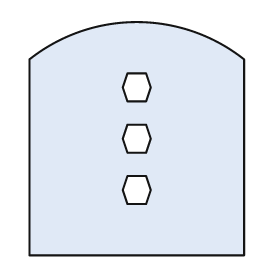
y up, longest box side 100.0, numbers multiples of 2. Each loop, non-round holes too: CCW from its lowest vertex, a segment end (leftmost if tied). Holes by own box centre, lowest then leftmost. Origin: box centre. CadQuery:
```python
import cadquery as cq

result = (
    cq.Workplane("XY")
    .moveTo(-46.0, -50.0)
    .lineTo(46.0, -50.0)
    .lineTo(46.0, 34.0)
    .threePointArc((0.0, 50.0), (-46.0, 34.0))
    .close()
    .moveTo(-4.0, -28.0)
    .lineTo(4.0, -28.0)
    .lineTo(6.0, -22.0)
    .lineTo(4.0, -16.0)
    .lineTo(-4.0, -16.0)
    .lineTo(-6.0, -22.0)
    .close()
    .moveTo(-4.0, -6.0)
    .lineTo(4.0, -6.0)
    .lineTo(6.0, 0.0)
    .lineTo(4.0, 6.0)
    .lineTo(-4.0, 6.0)
    .lineTo(-6.0, 0.0)
    .close()
    .moveTo(-4.0, 16.0)
    .lineTo(4.0, 16.0)
    .lineTo(6.0, 22.0)
    .lineTo(4.0, 28.0)
    .lineTo(-4.0, 28.0)
    .lineTo(-6.0, 22.0)
    .close()
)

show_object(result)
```